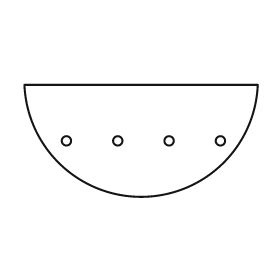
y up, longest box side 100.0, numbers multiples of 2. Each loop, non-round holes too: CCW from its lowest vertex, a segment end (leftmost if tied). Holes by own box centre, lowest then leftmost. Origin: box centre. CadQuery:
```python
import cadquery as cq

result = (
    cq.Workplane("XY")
    .moveTo(-50.0, 24.0)
    .threePointArc((0.0, -24.0), (50.0, 24.0))
    .close()
    .moveTo(-32.0, 0.0)
    .circle(2.0)
    .moveTo(-10.0, 0.0)
    .circle(2.0)
    .moveTo(12.0, 0.0)
    .circle(2.0)
    .moveTo(34.0, 0.0)
    .circle(2.0)
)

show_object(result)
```